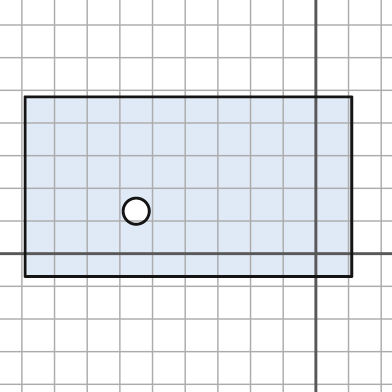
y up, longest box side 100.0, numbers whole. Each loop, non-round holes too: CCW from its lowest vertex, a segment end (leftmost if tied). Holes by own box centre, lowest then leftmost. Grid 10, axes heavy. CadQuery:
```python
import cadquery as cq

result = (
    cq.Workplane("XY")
    .moveTo(-89.0, -7.0)
    .lineTo(11.0, -7.0)
    .lineTo(11.0, 48.0)
    .lineTo(-89.0, 48.0)
    .close()
    .moveTo(-55.0, 13.0)
    .circle(4.0)
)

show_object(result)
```